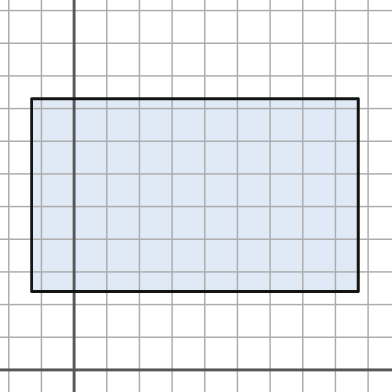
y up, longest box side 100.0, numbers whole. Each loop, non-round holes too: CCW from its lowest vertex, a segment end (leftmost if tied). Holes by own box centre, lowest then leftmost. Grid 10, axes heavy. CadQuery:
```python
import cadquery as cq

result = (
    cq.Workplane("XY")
    .moveTo(-13.0, 24.0)
    .lineTo(87.0, 24.0)
    .lineTo(87.0, 83.0)
    .lineTo(-13.0, 83.0)
    .close()
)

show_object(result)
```